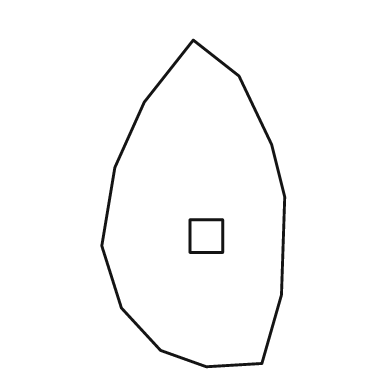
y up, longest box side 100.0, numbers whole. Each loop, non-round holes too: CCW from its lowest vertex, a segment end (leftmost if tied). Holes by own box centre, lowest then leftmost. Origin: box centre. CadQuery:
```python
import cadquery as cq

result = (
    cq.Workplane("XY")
    .moveTo(4.0, -50.0)
    .lineTo(21.0, -49.0)
    .lineTo(27.0, -28.0)
    .lineTo(28.0, 2.0)
    .lineTo(24.0, 18.0)
    .lineTo(14.0, 39.0)
    .lineTo(0.0, 50.0)
    .lineTo(-15.0, 31.0)
    .lineTo(-24.0, 11.0)
    .lineTo(-28.0, -13.0)
    .lineTo(-22.0, -32.0)
    .lineTo(-10.0, -45.0)
    .close()
    .moveTo(-1.0, -15.0)
    .lineTo(9.0, -15.0)
    .lineTo(9.0, -5.0)
    .lineTo(-1.0, -5.0)
    .close()
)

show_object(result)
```